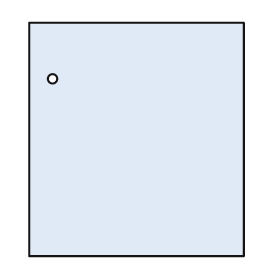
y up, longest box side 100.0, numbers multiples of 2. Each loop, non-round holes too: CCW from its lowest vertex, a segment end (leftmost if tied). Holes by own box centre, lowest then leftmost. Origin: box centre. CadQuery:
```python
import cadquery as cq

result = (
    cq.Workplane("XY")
    .moveTo(-46.0, -50.0)
    .lineTo(46.0, -50.0)
    .lineTo(46.0, 50.0)
    .lineTo(-46.0, 50.0)
    .close()
    .moveTo(-36.0, 26.0)
    .circle(2.0)
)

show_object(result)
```